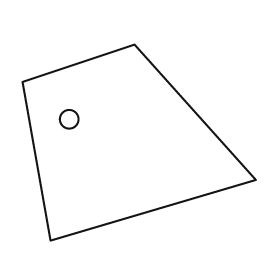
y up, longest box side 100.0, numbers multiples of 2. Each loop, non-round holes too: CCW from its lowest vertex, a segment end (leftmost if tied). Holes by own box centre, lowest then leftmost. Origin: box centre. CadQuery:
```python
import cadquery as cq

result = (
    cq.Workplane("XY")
    .moveTo(-38.0, -42.0)
    .lineTo(50.0, -16.0)
    .lineTo(-2.0, 42.0)
    .lineTo(-50.0, 26.0)
    .close()
    .moveTo(-30.0, 10.0)
    .circle(4.0)
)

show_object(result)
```